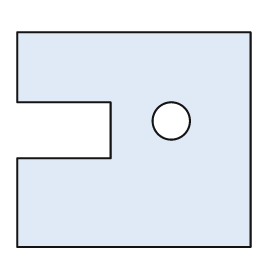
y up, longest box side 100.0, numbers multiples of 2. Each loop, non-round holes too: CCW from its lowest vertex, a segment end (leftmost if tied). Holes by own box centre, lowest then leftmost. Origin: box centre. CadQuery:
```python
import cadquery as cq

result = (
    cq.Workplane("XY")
    .moveTo(-50.0, -46.0)
    .lineTo(50.0, -46.0)
    .lineTo(50.0, 46.0)
    .lineTo(-50.0, 46.0)
    .lineTo(-50.0, 16.0)
    .lineTo(-10.0, 16.0)
    .lineTo(-10.0, -8.0)
    .lineTo(-50.0, -8.0)
    .close()
    .moveTo(16.0, 8.0)
    .circle(8.0)
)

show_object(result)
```